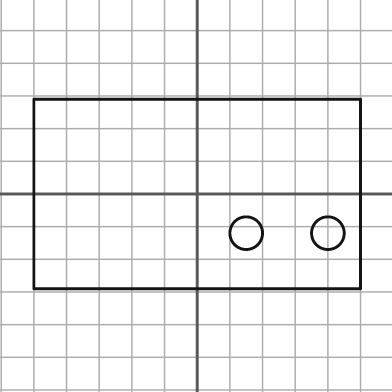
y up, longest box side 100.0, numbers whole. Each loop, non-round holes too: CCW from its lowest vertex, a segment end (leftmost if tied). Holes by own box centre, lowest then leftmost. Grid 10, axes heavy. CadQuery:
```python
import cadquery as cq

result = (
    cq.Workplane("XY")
    .moveTo(-50.0, -29.0)
    .lineTo(50.0, -29.0)
    .lineTo(50.0, 29.0)
    .lineTo(-50.0, 29.0)
    .close()
    .moveTo(15.0, -12.0)
    .circle(5.0)
    .moveTo(40.0, -12.0)
    .circle(5.0)
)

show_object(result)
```